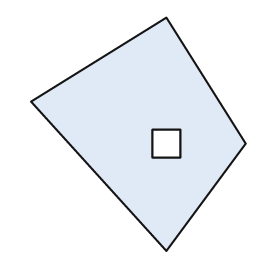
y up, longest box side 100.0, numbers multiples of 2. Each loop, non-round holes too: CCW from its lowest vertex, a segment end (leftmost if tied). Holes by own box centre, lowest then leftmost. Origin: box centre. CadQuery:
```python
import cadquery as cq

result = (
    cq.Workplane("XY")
    .moveTo(12.0, -50.0)
    .lineTo(46.0, -4.0)
    .lineTo(12.0, 50.0)
    .lineTo(-46.0, 14.0)
    .close()
    .moveTo(6.0, -10.0)
    .lineTo(18.0, -10.0)
    .lineTo(18.0, 2.0)
    .lineTo(6.0, 2.0)
    .close()
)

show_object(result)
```